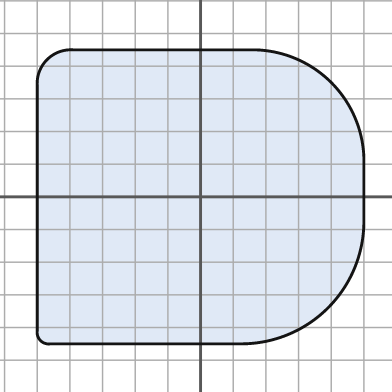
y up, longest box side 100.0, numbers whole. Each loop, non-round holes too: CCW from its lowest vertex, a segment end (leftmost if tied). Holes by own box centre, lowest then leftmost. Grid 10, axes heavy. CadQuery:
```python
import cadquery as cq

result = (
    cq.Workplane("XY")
    .moveTo(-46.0, -45.0)
    .lineTo(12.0, -45.0)
    .threePointArc((39.0, -34.0), (50.0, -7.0))
    .lineTo(50.0, 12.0)
    .threePointArc((40.0, 35.0), (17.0, 45.0))
    .lineTo(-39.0, 45.0)
    .threePointArc((-47.0, 42.0), (-50.0, 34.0))
    .lineTo(-50.0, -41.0)
    .threePointArc((-49.0, -44.0), (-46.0, -45.0))
    .close()
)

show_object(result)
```